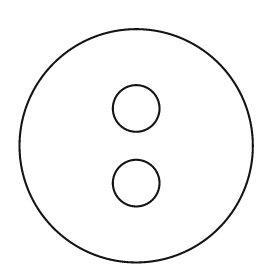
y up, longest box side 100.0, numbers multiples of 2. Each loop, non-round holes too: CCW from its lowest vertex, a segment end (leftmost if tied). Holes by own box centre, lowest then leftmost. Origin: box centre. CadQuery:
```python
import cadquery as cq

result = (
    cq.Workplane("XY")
    .moveTo(0.0, 0.0)
    .circle(50.0)
    .moveTo(0.0, -16.0)
    .circle(10.0)
    .moveTo(0.0, 16.0)
    .circle(10.0)
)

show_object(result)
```